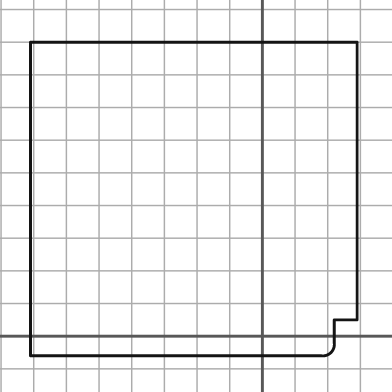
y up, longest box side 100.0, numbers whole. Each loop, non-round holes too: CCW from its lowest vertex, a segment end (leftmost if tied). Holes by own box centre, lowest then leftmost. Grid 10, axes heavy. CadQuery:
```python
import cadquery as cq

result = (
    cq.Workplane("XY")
    .moveTo(-71.0, -6.0)
    .lineTo(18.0, -6.0)
    .threePointArc((21.0, -5.0), (22.0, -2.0))
    .lineTo(22.0, 5.0)
    .lineTo(29.0, 5.0)
    .lineTo(29.0, 90.0)
    .lineTo(-71.0, 90.0)
    .close()
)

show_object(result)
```